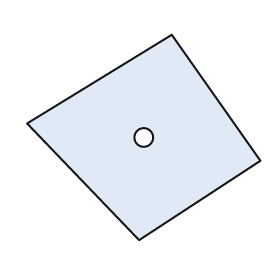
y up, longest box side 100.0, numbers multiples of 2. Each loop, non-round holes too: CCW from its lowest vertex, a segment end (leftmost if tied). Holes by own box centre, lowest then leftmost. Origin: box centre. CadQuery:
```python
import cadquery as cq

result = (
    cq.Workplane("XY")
    .moveTo(-2.0, -44.0)
    .lineTo(50.0, -10.0)
    .lineTo(12.0, 44.0)
    .lineTo(-50.0, 6.0)
    .close()
    .moveTo(0.0, 0.0)
    .circle(4.0)
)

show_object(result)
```